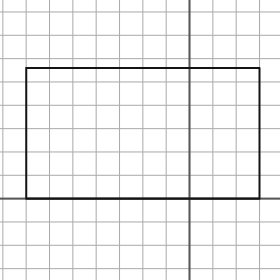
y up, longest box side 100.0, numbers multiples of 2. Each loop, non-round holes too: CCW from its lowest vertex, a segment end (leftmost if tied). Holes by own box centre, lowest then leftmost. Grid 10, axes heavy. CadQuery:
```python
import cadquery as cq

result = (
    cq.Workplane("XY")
    .moveTo(-70.0, 0.0)
    .lineTo(30.0, 0.0)
    .lineTo(30.0, 56.0)
    .lineTo(-70.0, 56.0)
    .close()
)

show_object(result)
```